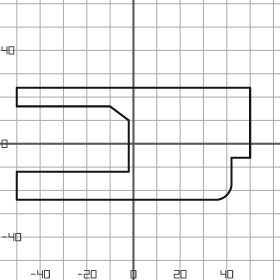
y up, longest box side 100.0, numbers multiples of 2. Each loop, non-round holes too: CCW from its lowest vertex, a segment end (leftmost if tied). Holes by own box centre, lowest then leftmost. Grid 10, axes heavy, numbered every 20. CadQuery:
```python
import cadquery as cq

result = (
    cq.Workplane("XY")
    .moveTo(-50.0, -24.0)
    .lineTo(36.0, -24.0)
    .threePointArc((40.0, -22.0), (42.0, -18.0))
    .lineTo(42.0, -6.0)
    .lineTo(50.0, -6.0)
    .lineTo(50.0, 24.0)
    .lineTo(-50.0, 24.0)
    .lineTo(-50.0, 16.0)
    .lineTo(-10.0, 16.0)
    .lineTo(-2.0, 10.0)
    .lineTo(-2.0, -12.0)
    .lineTo(-50.0, -12.0)
    .close()
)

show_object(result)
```